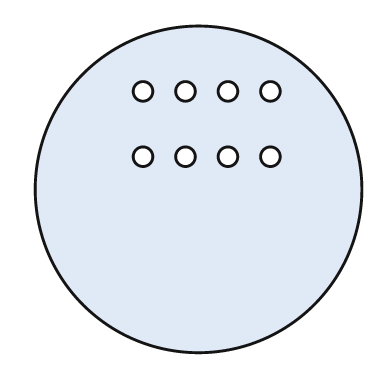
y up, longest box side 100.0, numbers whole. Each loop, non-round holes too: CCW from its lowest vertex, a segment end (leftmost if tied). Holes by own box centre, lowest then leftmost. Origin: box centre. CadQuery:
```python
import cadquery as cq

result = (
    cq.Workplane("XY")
    .moveTo(0.0, 0.0)
    .circle(50.0)
    .moveTo(-17.0, 10.0)
    .circle(3.0)
    .moveTo(-4.0, 10.0)
    .circle(3.0)
    .moveTo(9.0, 10.0)
    .circle(3.0)
    .moveTo(22.0, 10.0)
    .circle(3.0)
    .moveTo(-17.0, 30.0)
    .circle(3.0)
    .moveTo(-4.0, 30.0)
    .circle(3.0)
    .moveTo(9.0, 30.0)
    .circle(3.0)
    .moveTo(22.0, 30.0)
    .circle(3.0)
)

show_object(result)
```